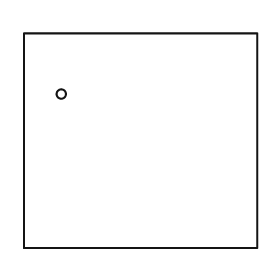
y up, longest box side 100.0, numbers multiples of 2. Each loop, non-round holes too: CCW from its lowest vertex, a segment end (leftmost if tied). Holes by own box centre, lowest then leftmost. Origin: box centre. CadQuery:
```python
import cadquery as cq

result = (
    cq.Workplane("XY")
    .moveTo(-50.0, -46.0)
    .lineTo(50.0, -46.0)
    .lineTo(50.0, 46.0)
    .lineTo(-50.0, 46.0)
    .close()
    .moveTo(-34.0, 20.0)
    .circle(2.0)
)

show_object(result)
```